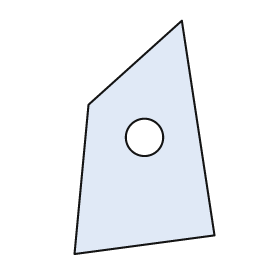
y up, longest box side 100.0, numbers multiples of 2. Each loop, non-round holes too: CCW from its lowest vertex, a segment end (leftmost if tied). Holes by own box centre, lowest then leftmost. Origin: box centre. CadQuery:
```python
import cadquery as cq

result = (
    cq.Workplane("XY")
    .moveTo(-30.0, -50.0)
    .lineTo(30.0, -42.0)
    .lineTo(16.0, 50.0)
    .lineTo(-24.0, 14.0)
    .close()
    .moveTo(0.0, 0.0)
    .circle(8.0)
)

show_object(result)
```